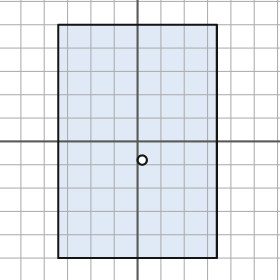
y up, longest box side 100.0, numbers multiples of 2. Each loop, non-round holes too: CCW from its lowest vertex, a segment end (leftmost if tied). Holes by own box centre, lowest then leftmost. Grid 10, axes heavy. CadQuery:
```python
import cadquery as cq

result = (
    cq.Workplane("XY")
    .moveTo(-34.0, -50.0)
    .lineTo(34.0, -50.0)
    .lineTo(34.0, 50.0)
    .lineTo(-34.0, 50.0)
    .close()
    .moveTo(2.0, -8.0)
    .circle(2.0)
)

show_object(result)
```